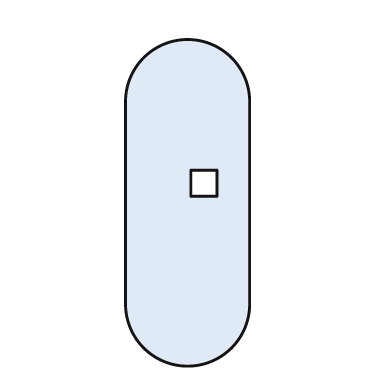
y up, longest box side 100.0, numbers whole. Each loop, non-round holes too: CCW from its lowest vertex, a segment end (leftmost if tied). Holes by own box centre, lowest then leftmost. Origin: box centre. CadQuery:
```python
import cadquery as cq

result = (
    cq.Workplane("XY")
    .moveTo(-19.0, -31.0)
    .threePointArc((0.0, -50.0), (19.0, -31.0))
    .lineTo(19.0, 31.0)
    .threePointArc((0.0, 50.0), (-19.0, 31.0))
    .close()
    .moveTo(1.0, 2.0)
    .lineTo(9.0, 2.0)
    .lineTo(9.0, 10.0)
    .lineTo(1.0, 10.0)
    .close()
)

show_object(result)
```